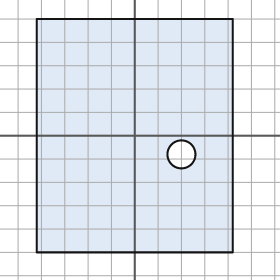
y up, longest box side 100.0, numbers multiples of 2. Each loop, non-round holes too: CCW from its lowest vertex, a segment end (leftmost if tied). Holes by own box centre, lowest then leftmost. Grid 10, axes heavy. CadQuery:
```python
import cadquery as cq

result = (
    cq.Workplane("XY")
    .moveTo(-42.0, -50.0)
    .lineTo(42.0, -50.0)
    .lineTo(42.0, 50.0)
    .lineTo(-42.0, 50.0)
    .close()
    .moveTo(20.0, -8.0)
    .circle(6.0)
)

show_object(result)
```